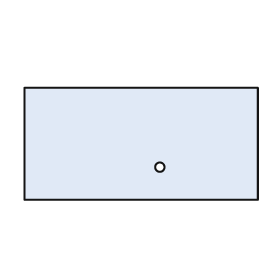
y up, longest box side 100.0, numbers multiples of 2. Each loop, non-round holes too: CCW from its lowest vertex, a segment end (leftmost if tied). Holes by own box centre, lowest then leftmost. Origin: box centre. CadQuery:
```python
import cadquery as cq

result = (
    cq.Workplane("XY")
    .moveTo(-50.0, -24.0)
    .lineTo(50.0, -24.0)
    .lineTo(50.0, 24.0)
    .lineTo(-50.0, 24.0)
    .close()
    .moveTo(8.0, -10.0)
    .circle(2.0)
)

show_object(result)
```